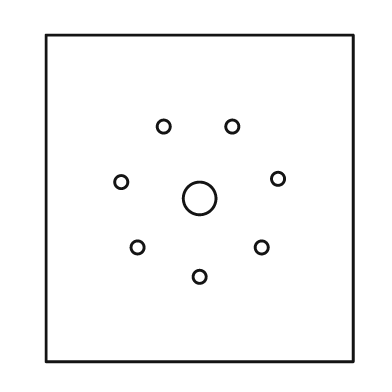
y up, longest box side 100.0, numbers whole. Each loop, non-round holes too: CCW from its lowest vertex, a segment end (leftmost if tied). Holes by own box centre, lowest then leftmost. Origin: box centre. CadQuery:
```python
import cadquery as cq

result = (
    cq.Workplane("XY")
    .moveTo(-47.0, -50.0)
    .lineTo(47.0, -50.0)
    .lineTo(47.0, 50.0)
    .lineTo(-47.0, 50.0)
    .close()
    .moveTo(0.0, -24.0)
    .circle(2.0)
    .moveTo(-19.0, -15.0)
    .circle(2.0)
    .moveTo(19.0, -15.0)
    .circle(2.0)
    .moveTo(0.0, 0.0)
    .circle(5.0)
    .moveTo(-24.0, 5.0)
    .circle(2.0)
    .moveTo(24.0, 6.0)
    .circle(2.0)
    .moveTo(-11.0, 22.0)
    .circle(2.0)
    .moveTo(10.0, 22.0)
    .circle(2.0)
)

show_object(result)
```